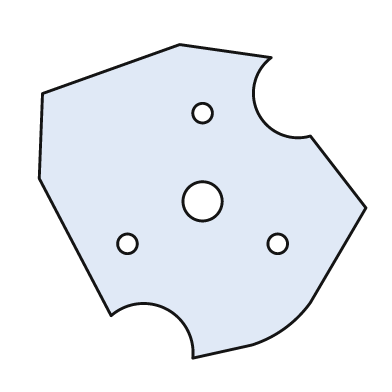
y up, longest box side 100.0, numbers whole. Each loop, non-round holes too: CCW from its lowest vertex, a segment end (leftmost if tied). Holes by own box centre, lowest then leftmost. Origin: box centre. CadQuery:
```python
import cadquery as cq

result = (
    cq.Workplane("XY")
    .moveTo(-3.0, -48.0)
    .lineTo(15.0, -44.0)
    .threePointArc((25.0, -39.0), (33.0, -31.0))
    .lineTo(50.0, -2.0)
    .lineTo(33.0, 20.0)
    .threePointArc((17.0, 27.0), (21.0, 44.0))
    .lineTo(-7.0, 48.0)
    .lineTo(-49.0, 33.0)
    .lineTo(-50.0, 7.0)
    .lineTo(-28.0, -35.0)
    .threePointArc((-11.0, -33.0), (-3.0, -48.0))
    .close()
    .moveTo(-23.0, -13.0)
    .circle(3.0)
    .moveTo(23.0, -13.0)
    .circle(3.0)
    .moveTo(0.0, 0.0)
    .circle(6.0)
    .moveTo(0.0, 27.0)
    .circle(3.0)
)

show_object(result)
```